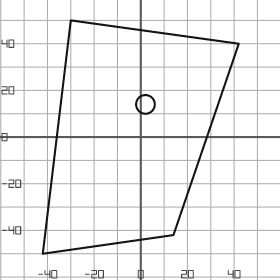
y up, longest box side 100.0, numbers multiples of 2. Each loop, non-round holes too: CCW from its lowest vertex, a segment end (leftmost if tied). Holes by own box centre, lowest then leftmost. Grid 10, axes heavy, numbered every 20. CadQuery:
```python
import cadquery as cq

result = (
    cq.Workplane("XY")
    .moveTo(-42.0, -50.0)
    .lineTo(14.0, -42.0)
    .lineTo(42.0, 40.0)
    .lineTo(-30.0, 50.0)
    .close()
    .moveTo(2.0, 14.0)
    .circle(4.0)
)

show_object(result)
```